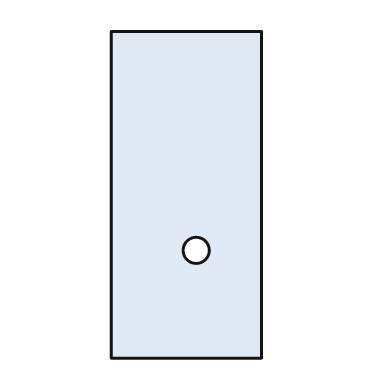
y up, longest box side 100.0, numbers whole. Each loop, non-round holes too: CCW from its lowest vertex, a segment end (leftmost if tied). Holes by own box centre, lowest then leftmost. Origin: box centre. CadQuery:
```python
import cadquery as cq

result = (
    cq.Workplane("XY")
    .moveTo(-23.0, -50.0)
    .lineTo(23.0, -50.0)
    .lineTo(23.0, 50.0)
    .lineTo(-23.0, 50.0)
    .close()
    .moveTo(3.0, -17.0)
    .circle(4.0)
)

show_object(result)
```